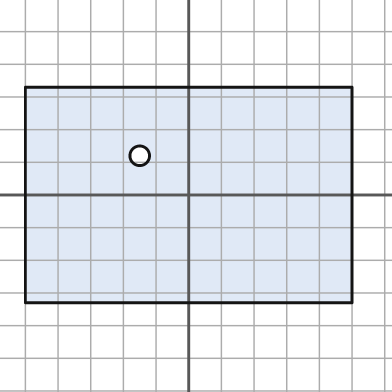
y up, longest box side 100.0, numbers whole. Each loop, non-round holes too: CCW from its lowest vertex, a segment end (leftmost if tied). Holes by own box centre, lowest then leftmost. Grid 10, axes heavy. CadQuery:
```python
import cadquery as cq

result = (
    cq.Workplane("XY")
    .moveTo(-50.0, -33.0)
    .lineTo(50.0, -33.0)
    .lineTo(50.0, 33.0)
    .lineTo(-50.0, 33.0)
    .close()
    .moveTo(-15.0, 12.0)
    .circle(3.0)
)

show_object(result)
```